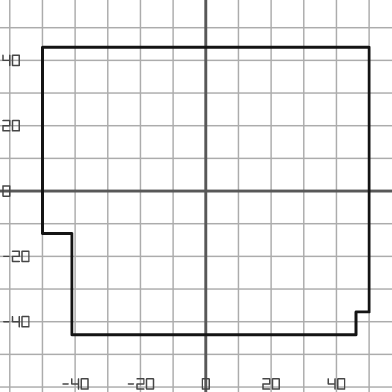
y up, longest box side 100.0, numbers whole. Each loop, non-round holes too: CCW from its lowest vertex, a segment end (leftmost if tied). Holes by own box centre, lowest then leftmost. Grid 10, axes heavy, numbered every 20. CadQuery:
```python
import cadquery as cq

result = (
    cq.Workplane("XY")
    .moveTo(-41.0, -44.0)
    .lineTo(46.0, -44.0)
    .lineTo(46.0, -37.0)
    .lineTo(50.0, -37.0)
    .lineTo(50.0, 44.0)
    .lineTo(-50.0, 44.0)
    .lineTo(-50.0, -13.0)
    .lineTo(-41.0, -13.0)
    .close()
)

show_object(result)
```